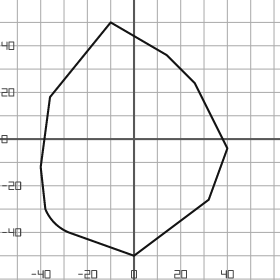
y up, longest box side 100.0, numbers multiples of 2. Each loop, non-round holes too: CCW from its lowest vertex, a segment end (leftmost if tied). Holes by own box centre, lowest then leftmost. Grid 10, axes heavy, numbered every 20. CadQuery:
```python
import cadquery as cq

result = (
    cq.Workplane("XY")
    .moveTo(0.0, -50.0)
    .lineTo(32.0, -26.0)
    .lineTo(40.0, -4.0)
    .lineTo(26.0, 24.0)
    .lineTo(14.0, 36.0)
    .lineTo(-10.0, 50.0)
    .lineTo(-36.0, 18.0)
    .lineTo(-40.0, -12.0)
    .lineTo(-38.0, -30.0)
    .threePointArc((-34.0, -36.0), (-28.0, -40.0))
    .close()
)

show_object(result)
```